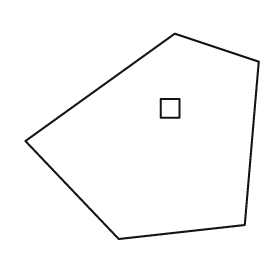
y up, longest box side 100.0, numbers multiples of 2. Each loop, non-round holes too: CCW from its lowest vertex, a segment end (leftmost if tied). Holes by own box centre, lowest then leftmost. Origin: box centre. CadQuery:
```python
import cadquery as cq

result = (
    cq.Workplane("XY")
    .moveTo(-10.0, -44.0)
    .lineTo(44.0, -38.0)
    .lineTo(50.0, 32.0)
    .lineTo(14.0, 44.0)
    .lineTo(-50.0, -2.0)
    .close()
    .moveTo(8.0, 8.0)
    .lineTo(16.0, 8.0)
    .lineTo(16.0, 16.0)
    .lineTo(8.0, 16.0)
    .close()
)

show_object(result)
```